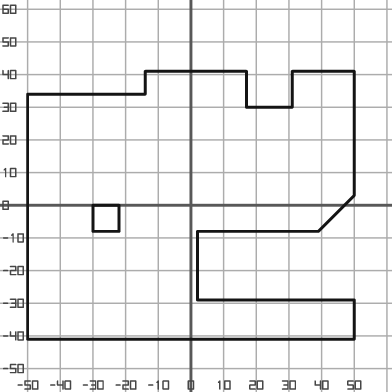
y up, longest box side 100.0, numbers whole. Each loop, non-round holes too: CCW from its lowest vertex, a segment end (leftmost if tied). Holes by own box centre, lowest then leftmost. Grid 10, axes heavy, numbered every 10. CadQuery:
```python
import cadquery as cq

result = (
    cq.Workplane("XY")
    .moveTo(-50.0, -41.0)
    .lineTo(50.0, -41.0)
    .lineTo(50.0, -29.0)
    .lineTo(2.0, -29.0)
    .lineTo(2.0, -8.0)
    .lineTo(39.0, -8.0)
    .lineTo(50.0, 3.0)
    .lineTo(50.0, 41.0)
    .lineTo(31.0, 41.0)
    .lineTo(31.0, 30.0)
    .lineTo(17.0, 30.0)
    .lineTo(17.0, 41.0)
    .lineTo(-14.0, 41.0)
    .lineTo(-14.0, 34.0)
    .lineTo(-50.0, 34.0)
    .close()
    .moveTo(-30.0, -8.0)
    .lineTo(-22.0, -8.0)
    .lineTo(-22.0, 0.0)
    .lineTo(-30.0, 0.0)
    .close()
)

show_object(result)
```